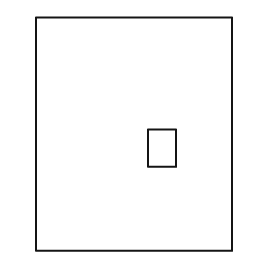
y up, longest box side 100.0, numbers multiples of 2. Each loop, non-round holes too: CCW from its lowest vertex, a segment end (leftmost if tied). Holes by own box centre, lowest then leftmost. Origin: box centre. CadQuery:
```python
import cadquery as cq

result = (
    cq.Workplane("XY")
    .moveTo(-42.0, -50.0)
    .lineTo(42.0, -50.0)
    .lineTo(42.0, 50.0)
    .lineTo(-42.0, 50.0)
    .close()
    .moveTo(6.0, -14.0)
    .lineTo(18.0, -14.0)
    .lineTo(18.0, 2.0)
    .lineTo(6.0, 2.0)
    .close()
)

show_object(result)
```